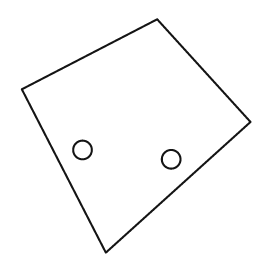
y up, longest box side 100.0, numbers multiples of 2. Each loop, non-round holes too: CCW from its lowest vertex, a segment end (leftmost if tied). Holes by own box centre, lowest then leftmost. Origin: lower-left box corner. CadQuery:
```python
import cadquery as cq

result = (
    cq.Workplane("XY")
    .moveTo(36.0, 0.0)
    .lineTo(98.0, 56.0)
    .lineTo(58.0, 100.0)
    .lineTo(0.0, 70.0)
    .close()
    .moveTo(64.0, 40.0)
    .circle(4.0)
    .moveTo(26.0, 44.0)
    .circle(4.0)
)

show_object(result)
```